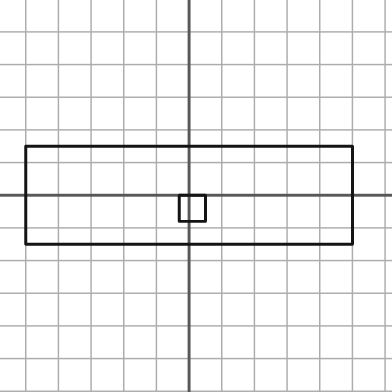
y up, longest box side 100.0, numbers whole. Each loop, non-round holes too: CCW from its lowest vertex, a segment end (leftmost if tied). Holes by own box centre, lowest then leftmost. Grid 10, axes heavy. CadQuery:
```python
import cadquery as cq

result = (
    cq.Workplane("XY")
    .moveTo(-50.0, -15.0)
    .lineTo(50.0, -15.0)
    .lineTo(50.0, 15.0)
    .lineTo(-50.0, 15.0)
    .close()
    .moveTo(-3.0, -8.0)
    .lineTo(5.0, -8.0)
    .lineTo(5.0, 0.0)
    .lineTo(-3.0, 0.0)
    .close()
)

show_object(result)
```